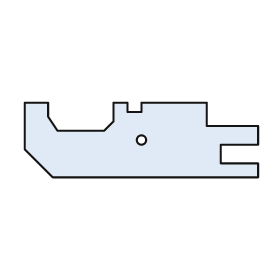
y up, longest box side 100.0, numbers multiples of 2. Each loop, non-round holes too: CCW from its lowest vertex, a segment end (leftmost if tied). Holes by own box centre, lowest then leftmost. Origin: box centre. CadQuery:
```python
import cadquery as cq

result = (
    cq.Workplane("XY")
    .moveTo(-38.0, -16.0)
    .lineTo(50.0, -16.0)
    .lineTo(50.0, -10.0)
    .lineTo(34.0, -10.0)
    .lineTo(34.0, -2.0)
    .lineTo(50.0, -2.0)
    .lineTo(50.0, 6.0)
    .lineTo(28.0, 6.0)
    .lineTo(28.0, 16.0)
    .lineTo(0.0, 16.0)
    .lineTo(0.0, 12.0)
    .lineTo(-6.0, 12.0)
    .lineTo(-6.0, 16.0)
    .lineTo(-12.0, 16.0)
    .lineTo(-12.0, 8.0)
    .lineTo(-16.0, 4.0)
    .lineTo(-36.0, 4.0)
    .lineTo(-40.0, 10.0)
    .lineTo(-40.0, 16.0)
    .lineTo(-50.0, 16.0)
    .lineTo(-50.0, -4.0)
    .close()
    .moveTo(0.0, 0.0)
    .circle(2.0)
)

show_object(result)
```